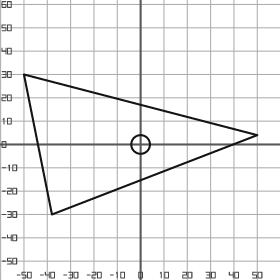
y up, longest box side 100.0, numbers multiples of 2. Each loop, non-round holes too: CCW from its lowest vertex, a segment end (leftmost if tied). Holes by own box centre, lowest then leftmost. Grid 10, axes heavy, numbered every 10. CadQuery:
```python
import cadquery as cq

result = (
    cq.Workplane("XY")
    .moveTo(-38.0, -30.0)
    .lineTo(50.0, 4.0)
    .lineTo(-50.0, 30.0)
    .close()
    .moveTo(0.0, 0.0)
    .circle(4.0)
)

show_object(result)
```